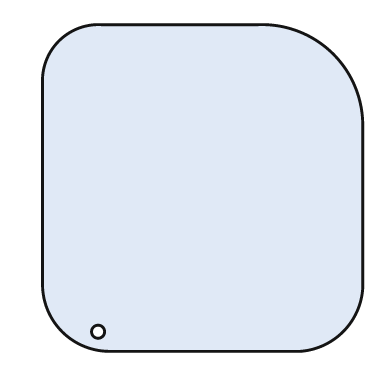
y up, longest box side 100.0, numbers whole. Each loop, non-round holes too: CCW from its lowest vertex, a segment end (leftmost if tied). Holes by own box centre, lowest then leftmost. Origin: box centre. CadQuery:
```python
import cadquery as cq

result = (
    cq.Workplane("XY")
    .moveTo(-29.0, -50.0)
    .lineTo(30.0, -50.0)
    .threePointArc((43.0, -44.0), (49.0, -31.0))
    .lineTo(49.0, 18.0)
    .threePointArc((40.0, 41.0), (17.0, 50.0))
    .lineTo(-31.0, 50.0)
    .threePointArc((-44.0, 45.0), (-49.0, 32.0))
    .lineTo(-49.0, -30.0)
    .threePointArc((-43.0, -44.0), (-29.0, -50.0))
    .close()
    .moveTo(-32.0, -44.0)
    .circle(2.0)
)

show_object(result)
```